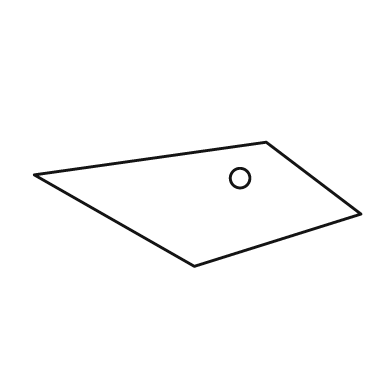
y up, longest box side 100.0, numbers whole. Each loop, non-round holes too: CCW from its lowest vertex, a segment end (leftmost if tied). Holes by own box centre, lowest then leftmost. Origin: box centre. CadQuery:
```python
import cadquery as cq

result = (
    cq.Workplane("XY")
    .moveTo(-1.0, -19.0)
    .lineTo(50.0, -3.0)
    .lineTo(21.0, 19.0)
    .lineTo(-50.0, 9.0)
    .close()
    .moveTo(13.0, 8.0)
    .circle(3.0)
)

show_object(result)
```